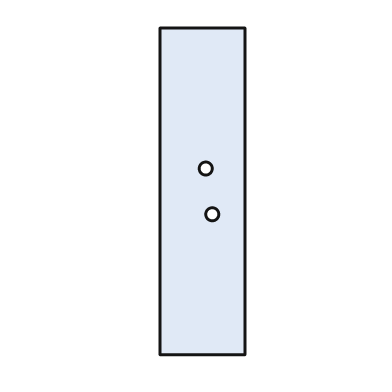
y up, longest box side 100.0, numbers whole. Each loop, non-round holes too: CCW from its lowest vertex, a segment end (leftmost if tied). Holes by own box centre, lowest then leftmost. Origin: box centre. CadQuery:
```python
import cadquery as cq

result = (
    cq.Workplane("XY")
    .moveTo(-13.0, -50.0)
    .lineTo(13.0, -50.0)
    .lineTo(13.0, 50.0)
    .lineTo(-13.0, 50.0)
    .close()
    .moveTo(3.0, -7.0)
    .circle(2.0)
    .moveTo(1.0, 7.0)
    .circle(2.0)
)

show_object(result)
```